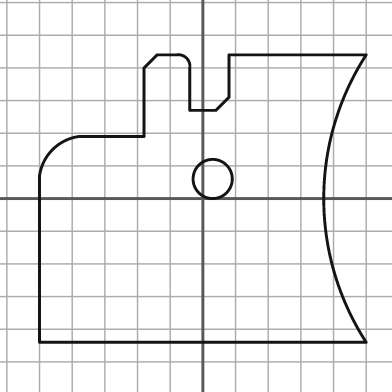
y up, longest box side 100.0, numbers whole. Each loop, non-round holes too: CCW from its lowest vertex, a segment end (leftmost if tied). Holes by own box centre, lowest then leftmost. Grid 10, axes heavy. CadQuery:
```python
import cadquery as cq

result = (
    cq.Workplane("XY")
    .moveTo(-50.0, -44.0)
    .lineTo(50.0, -44.0)
    .threePointArc((37.0, 0.0), (50.0, 44.0))
    .lineTo(8.0, 44.0)
    .lineTo(8.0, 31.0)
    .lineTo(4.0, 27.0)
    .lineTo(-4.0, 27.0)
    .lineTo(-4.0, 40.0)
    .threePointArc((-5.0, 43.0), (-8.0, 44.0))
    .lineTo(-14.0, 44.0)
    .lineTo(-18.0, 40.0)
    .lineTo(-18.0, 19.0)
    .lineTo(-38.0, 19.0)
    .threePointArc((-46.0, 15.0), (-50.0, 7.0))
    .close()
    .moveTo(3.0, 6.0)
    .circle(6.0)
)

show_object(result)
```